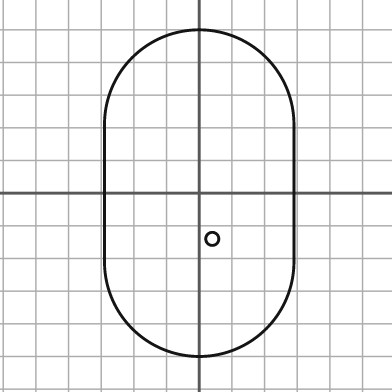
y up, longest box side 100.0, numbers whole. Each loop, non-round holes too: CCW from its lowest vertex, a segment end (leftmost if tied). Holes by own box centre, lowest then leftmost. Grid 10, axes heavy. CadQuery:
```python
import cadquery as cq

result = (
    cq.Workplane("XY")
    .moveTo(-29.0, -21.0)
    .threePointArc((0.0, -50.0), (29.0, -21.0))
    .lineTo(29.0, 21.0)
    .threePointArc((0.0, 50.0), (-29.0, 21.0))
    .close()
    .moveTo(4.0, -14.0)
    .circle(2.0)
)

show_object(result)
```